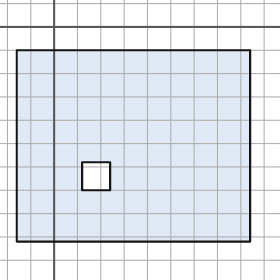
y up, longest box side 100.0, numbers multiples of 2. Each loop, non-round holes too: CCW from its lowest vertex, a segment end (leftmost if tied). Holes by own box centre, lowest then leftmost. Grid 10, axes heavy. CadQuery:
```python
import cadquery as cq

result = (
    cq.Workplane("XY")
    .moveTo(-16.0, -92.0)
    .lineTo(84.0, -92.0)
    .lineTo(84.0, -10.0)
    .lineTo(-16.0, -10.0)
    .close()
    .moveTo(12.0, -70.0)
    .lineTo(24.0, -70.0)
    .lineTo(24.0, -58.0)
    .lineTo(12.0, -58.0)
    .close()
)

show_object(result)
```